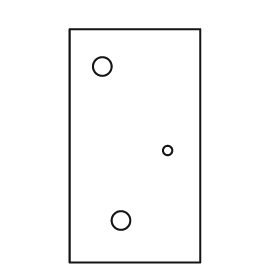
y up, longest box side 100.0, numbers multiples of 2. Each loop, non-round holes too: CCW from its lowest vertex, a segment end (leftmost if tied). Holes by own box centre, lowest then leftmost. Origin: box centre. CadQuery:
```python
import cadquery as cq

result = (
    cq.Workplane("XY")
    .moveTo(-28.0, -50.0)
    .lineTo(28.0, -50.0)
    .lineTo(28.0, 50.0)
    .lineTo(-28.0, 50.0)
    .close()
    .moveTo(-6.0, -32.0)
    .circle(4.0)
    .moveTo(14.0, -2.0)
    .circle(2.0)
    .moveTo(-14.0, 34.0)
    .circle(4.0)
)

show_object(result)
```